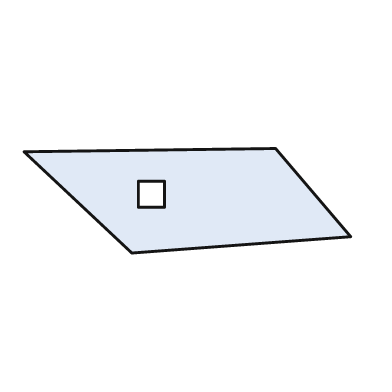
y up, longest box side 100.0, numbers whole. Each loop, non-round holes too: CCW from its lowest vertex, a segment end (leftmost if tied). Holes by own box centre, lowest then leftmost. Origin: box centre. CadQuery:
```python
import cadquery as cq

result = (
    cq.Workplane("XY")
    .moveTo(-17.0, -16.0)
    .lineTo(50.0, -11.0)
    .lineTo(27.0, 16.0)
    .lineTo(-50.0, 15.0)
    .close()
    .moveTo(-15.0, -2.0)
    .lineTo(-7.0, -2.0)
    .lineTo(-7.0, 6.0)
    .lineTo(-15.0, 6.0)
    .close()
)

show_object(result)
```